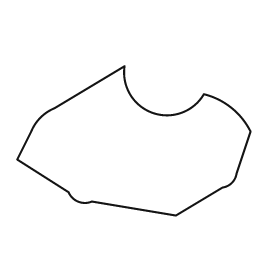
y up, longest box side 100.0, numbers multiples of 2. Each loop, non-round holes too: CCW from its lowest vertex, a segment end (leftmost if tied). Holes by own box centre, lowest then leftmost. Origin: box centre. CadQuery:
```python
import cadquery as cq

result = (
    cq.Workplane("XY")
    .moveTo(18.0, -32.0)
    .lineTo(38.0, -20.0)
    .threePointArc((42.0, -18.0), (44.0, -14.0))
    .lineTo(50.0, 4.0)
    .threePointArc((42.0, 14.0), (30.0, 20.0))
    .threePointArc((8.0, 12.0), (-4.0, 32.0))
    .lineTo(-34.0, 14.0)
    .threePointArc((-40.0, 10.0), (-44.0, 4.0))
    .lineTo(-50.0, -8.0)
    .lineTo(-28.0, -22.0)
    .threePointArc((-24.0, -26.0), (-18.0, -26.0))
    .close()
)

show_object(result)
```